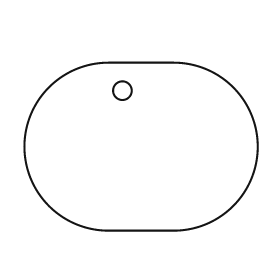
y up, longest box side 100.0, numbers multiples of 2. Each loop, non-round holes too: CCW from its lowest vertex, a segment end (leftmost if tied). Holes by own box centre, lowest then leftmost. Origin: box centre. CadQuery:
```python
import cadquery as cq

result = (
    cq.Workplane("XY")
    .moveTo(-14.0, -36.0)
    .lineTo(14.0, -36.0)
    .threePointArc((50.0, 0.0), (14.0, 36.0))
    .lineTo(-14.0, 36.0)
    .threePointArc((-50.0, 0.0), (-14.0, -36.0))
    .close()
    .moveTo(-8.0, 24.0)
    .circle(4.0)
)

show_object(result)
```